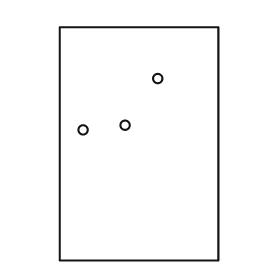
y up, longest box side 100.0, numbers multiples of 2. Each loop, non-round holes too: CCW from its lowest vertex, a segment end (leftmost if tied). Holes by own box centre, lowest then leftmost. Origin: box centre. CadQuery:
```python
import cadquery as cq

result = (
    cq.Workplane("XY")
    .moveTo(-34.0, -50.0)
    .lineTo(34.0, -50.0)
    .lineTo(34.0, 50.0)
    .lineTo(-34.0, 50.0)
    .close()
    .moveTo(-24.0, 6.0)
    .circle(2.0)
    .moveTo(-6.0, 8.0)
    .circle(2.0)
    .moveTo(8.0, 28.0)
    .circle(2.0)
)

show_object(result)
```